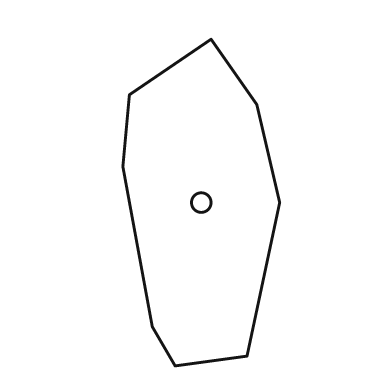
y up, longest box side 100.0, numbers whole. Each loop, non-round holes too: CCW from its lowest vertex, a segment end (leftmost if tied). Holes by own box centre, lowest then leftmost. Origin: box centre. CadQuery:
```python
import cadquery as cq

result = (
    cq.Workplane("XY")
    .moveTo(-8.0, -50.0)
    .lineTo(14.0, -47.0)
    .lineTo(24.0, 0.0)
    .lineTo(17.0, 30.0)
    .lineTo(3.0, 50.0)
    .lineTo(-22.0, 33.0)
    .lineTo(-24.0, 11.0)
    .lineTo(-15.0, -38.0)
    .close()
    .moveTo(0.0, 0.0)
    .circle(3.0)
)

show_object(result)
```